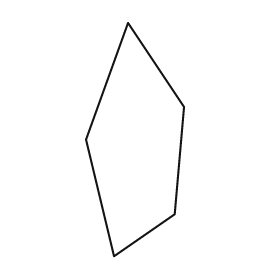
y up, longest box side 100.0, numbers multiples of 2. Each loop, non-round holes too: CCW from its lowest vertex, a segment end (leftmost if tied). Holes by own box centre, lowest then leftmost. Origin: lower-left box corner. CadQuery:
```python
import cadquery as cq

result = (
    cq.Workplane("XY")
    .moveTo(12.0, 0.0)
    .lineTo(38.0, 18.0)
    .lineTo(42.0, 64.0)
    .lineTo(18.0, 100.0)
    .lineTo(0.0, 50.0)
    .close()
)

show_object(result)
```